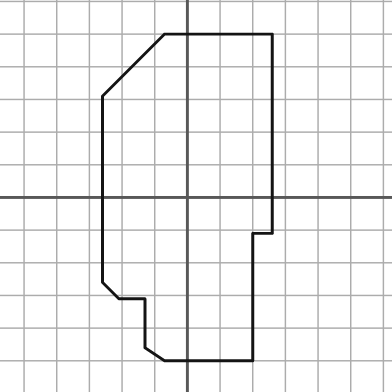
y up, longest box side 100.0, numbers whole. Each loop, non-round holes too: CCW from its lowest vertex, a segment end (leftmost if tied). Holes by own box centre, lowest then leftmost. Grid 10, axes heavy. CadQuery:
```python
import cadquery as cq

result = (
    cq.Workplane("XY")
    .moveTo(-7.0, -50.0)
    .lineTo(20.0, -50.0)
    .lineTo(20.0, -11.0)
    .lineTo(26.0, -11.0)
    .lineTo(26.0, 50.0)
    .lineTo(-7.0, 50.0)
    .lineTo(-26.0, 31.0)
    .lineTo(-26.0, -26.0)
    .lineTo(-21.0, -31.0)
    .lineTo(-13.0, -31.0)
    .lineTo(-13.0, -46.0)
    .close()
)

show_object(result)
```